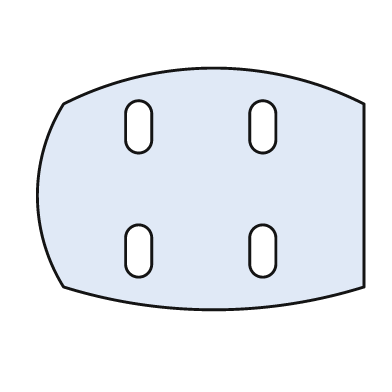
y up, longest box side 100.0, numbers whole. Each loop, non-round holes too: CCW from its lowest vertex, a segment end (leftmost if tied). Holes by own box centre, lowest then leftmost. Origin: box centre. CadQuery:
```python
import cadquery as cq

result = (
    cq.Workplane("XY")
    .moveTo(-42.0, -30.0)
    .threePointArc((4.0, -37.0), (50.0, -30.0))
    .lineTo(50.0, 26.0)
    .threePointArc((4.0, 37.0), (-42.0, 26.0))
    .threePointArc((-50.0, -2.0), (-42.0, -30.0))
    .close()
    .moveTo(-23.0, -23.0)
    .threePointArc((-19.0, -27.0), (-15.0, -23.0))
    .lineTo(-15.0, -15.0)
    .threePointArc((-19.0, -11.0), (-23.0, -15.0))
    .close()
    .moveTo(15.0, -23.0)
    .threePointArc((19.0, -27.0), (23.0, -23.0))
    .lineTo(23.0, -15.0)
    .threePointArc((19.0, -11.0), (15.0, -15.0))
    .close()
    .moveTo(-23.0, 15.0)
    .threePointArc((-19.0, 11.0), (-15.0, 15.0))
    .lineTo(-15.0, 23.0)
    .threePointArc((-19.0, 27.0), (-23.0, 23.0))
    .close()
    .moveTo(15.0, 15.0)
    .threePointArc((19.0, 11.0), (23.0, 15.0))
    .lineTo(23.0, 23.0)
    .threePointArc((19.0, 27.0), (15.0, 23.0))
    .close()
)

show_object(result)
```